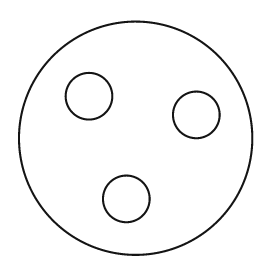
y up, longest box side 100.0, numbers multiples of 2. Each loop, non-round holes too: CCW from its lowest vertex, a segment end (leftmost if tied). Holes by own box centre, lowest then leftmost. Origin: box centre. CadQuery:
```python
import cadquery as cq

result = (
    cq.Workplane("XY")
    .moveTo(0.0, 0.0)
    .circle(50.0)
    .moveTo(-4.0, -26.0)
    .circle(10.0)
    .moveTo(26.0, 10.0)
    .circle(10.0)
    .moveTo(-20.0, 18.0)
    .circle(10.0)
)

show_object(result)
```